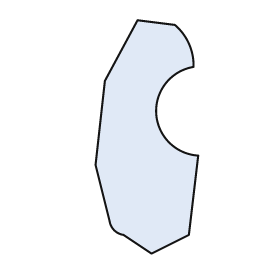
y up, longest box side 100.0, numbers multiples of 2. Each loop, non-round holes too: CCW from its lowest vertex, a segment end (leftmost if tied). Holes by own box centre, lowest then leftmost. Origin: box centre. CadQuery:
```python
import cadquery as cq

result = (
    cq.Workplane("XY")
    .moveTo(2.0, -50.0)
    .lineTo(18.0, -42.0)
    .lineTo(22.0, -8.0)
    .threePointArc((4.0, 10.0), (20.0, 30.0))
    .threePointArc((18.0, 40.0), (12.0, 48.0))
    .lineTo(-4.0, 50.0)
    .lineTo(-18.0, 24.0)
    .lineTo(-22.0, -12.0)
    .lineTo(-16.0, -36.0)
    .threePointArc((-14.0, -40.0), (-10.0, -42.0))
    .close()
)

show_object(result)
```